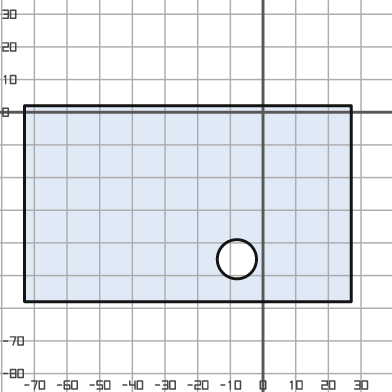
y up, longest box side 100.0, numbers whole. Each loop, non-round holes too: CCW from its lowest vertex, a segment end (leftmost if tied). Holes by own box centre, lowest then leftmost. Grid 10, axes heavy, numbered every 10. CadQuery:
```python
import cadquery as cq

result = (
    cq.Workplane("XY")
    .moveTo(-73.0, -58.0)
    .lineTo(27.0, -58.0)
    .lineTo(27.0, 2.0)
    .lineTo(-73.0, 2.0)
    .close()
    .moveTo(-8.0, -45.0)
    .circle(6.0)
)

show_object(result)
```